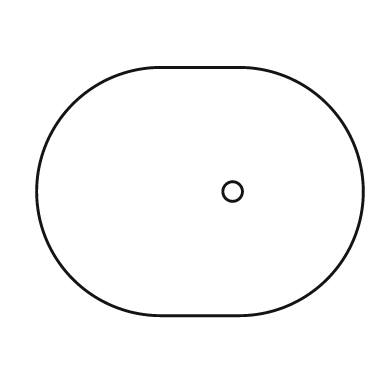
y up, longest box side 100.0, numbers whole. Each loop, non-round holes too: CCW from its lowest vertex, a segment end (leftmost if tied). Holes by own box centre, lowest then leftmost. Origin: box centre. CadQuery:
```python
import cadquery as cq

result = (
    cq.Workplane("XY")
    .moveTo(-12.0, -38.0)
    .lineTo(12.0, -38.0)
    .threePointArc((50.0, 0.0), (12.0, 38.0))
    .lineTo(-12.0, 38.0)
    .threePointArc((-50.0, 0.0), (-12.0, -38.0))
    .close()
    .moveTo(10.0, 0.0)
    .circle(3.0)
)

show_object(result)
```